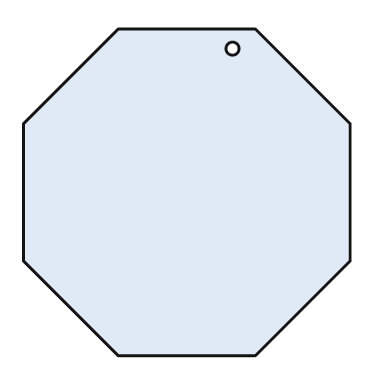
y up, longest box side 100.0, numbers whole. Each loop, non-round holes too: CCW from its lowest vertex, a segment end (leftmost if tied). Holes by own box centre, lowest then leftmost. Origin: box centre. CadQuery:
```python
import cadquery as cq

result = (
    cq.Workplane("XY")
    .moveTo(-21.0, -50.0)
    .lineTo(21.0, -50.0)
    .lineTo(50.0, -21.0)
    .lineTo(50.0, 21.0)
    .lineTo(21.0, 50.0)
    .lineTo(-21.0, 50.0)
    .lineTo(-50.0, 21.0)
    .lineTo(-50.0, -21.0)
    .close()
    .moveTo(14.0, 44.0)
    .circle(2.0)
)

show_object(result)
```